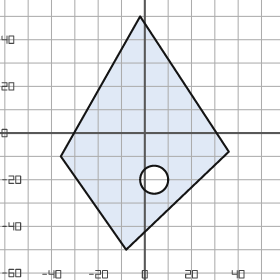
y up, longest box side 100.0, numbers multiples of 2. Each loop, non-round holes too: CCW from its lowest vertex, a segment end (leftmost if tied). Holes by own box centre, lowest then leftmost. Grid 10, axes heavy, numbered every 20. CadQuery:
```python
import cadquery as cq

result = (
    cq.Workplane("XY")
    .moveTo(-8.0, -50.0)
    .lineTo(36.0, -8.0)
    .lineTo(-2.0, 50.0)
    .lineTo(-36.0, -10.0)
    .close()
    .moveTo(4.0, -20.0)
    .circle(6.0)
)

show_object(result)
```